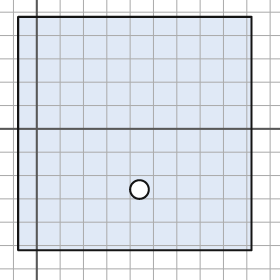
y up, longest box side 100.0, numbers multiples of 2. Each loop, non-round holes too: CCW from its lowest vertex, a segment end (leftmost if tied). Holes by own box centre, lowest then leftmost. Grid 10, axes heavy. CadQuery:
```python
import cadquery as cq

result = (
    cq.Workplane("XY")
    .moveTo(-8.0, -52.0)
    .lineTo(92.0, -52.0)
    .lineTo(92.0, 48.0)
    .lineTo(-8.0, 48.0)
    .close()
    .moveTo(44.0, -26.0)
    .circle(4.0)
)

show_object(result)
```